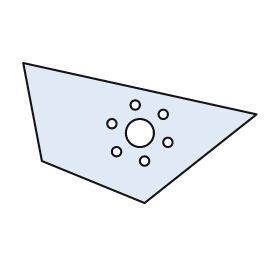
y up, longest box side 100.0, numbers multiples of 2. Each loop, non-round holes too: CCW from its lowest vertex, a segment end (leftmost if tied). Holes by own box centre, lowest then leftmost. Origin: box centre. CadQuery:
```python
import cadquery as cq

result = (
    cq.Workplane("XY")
    .moveTo(2.0, -30.0)
    .lineTo(50.0, 8.0)
    .lineTo(-50.0, 30.0)
    .lineTo(-42.0, -12.0)
    .close()
    .moveTo(2.0, -12.0)
    .circle(2.0)
    .moveTo(-10.0, -8.0)
    .circle(2.0)
    .moveTo(12.0, -4.0)
    .circle(2.0)
    .moveTo(0.0, 0.0)
    .circle(6.0)
    .moveTo(-12.0, 4.0)
    .circle(2.0)
    .moveTo(10.0, 8.0)
    .circle(2.0)
    .moveTo(-2.0, 12.0)
    .circle(2.0)
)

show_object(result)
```